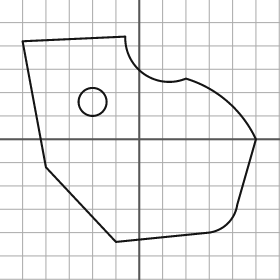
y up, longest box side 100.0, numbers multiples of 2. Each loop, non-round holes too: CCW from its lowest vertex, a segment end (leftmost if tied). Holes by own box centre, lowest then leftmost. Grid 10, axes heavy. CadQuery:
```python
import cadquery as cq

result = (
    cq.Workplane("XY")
    .moveTo(-10.0, -44.0)
    .lineTo(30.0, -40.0)
    .threePointArc((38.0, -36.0), (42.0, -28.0))
    .lineTo(50.0, 0.0)
    .threePointArc((38.0, 16.0), (20.0, 26.0))
    .threePointArc((2.0, 28.0), (-6.0, 44.0))
    .lineTo(-50.0, 42.0)
    .lineTo(-40.0, -12.0)
    .close()
    .moveTo(-20.0, 16.0)
    .circle(6.0)
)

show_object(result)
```